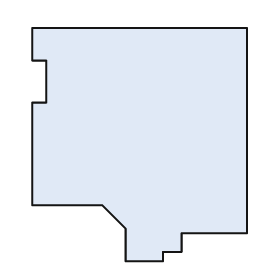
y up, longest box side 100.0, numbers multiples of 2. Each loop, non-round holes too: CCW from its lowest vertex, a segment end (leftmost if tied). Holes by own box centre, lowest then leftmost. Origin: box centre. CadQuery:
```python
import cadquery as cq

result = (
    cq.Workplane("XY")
    .moveTo(-6.0, -50.0)
    .lineTo(10.0, -50.0)
    .lineTo(10.0, -46.0)
    .lineTo(18.0, -46.0)
    .lineTo(18.0, -38.0)
    .lineTo(46.0, -38.0)
    .lineTo(46.0, 50.0)
    .lineTo(-46.0, 50.0)
    .lineTo(-46.0, 36.0)
    .lineTo(-40.0, 36.0)
    .lineTo(-40.0, 18.0)
    .lineTo(-46.0, 18.0)
    .lineTo(-46.0, -26.0)
    .lineTo(-16.0, -26.0)
    .lineTo(-6.0, -36.0)
    .close()
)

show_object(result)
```